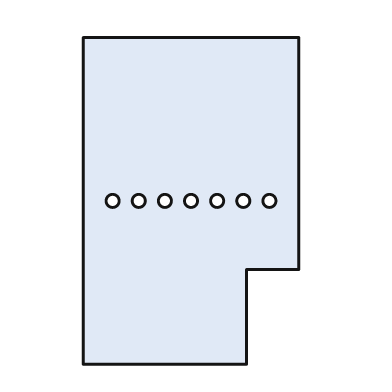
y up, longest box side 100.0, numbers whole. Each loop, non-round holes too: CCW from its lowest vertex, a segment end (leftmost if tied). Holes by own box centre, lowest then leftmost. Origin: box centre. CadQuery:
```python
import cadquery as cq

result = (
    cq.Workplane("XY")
    .moveTo(-33.0, -50.0)
    .lineTo(17.0, -50.0)
    .lineTo(17.0, -21.0)
    .lineTo(33.0, -21.0)
    .lineTo(33.0, 50.0)
    .lineTo(-33.0, 50.0)
    .close()
    .moveTo(-24.0, 0.0)
    .circle(2.0)
    .moveTo(-16.0, 0.0)
    .circle(2.0)
    .moveTo(-8.0, 0.0)
    .circle(2.0)
    .moveTo(0.0, 0.0)
    .circle(2.0)
    .moveTo(8.0, 0.0)
    .circle(2.0)
    .moveTo(16.0, 0.0)
    .circle(2.0)
    .moveTo(24.0, 0.0)
    .circle(2.0)
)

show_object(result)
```